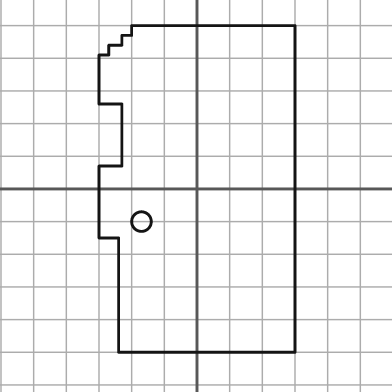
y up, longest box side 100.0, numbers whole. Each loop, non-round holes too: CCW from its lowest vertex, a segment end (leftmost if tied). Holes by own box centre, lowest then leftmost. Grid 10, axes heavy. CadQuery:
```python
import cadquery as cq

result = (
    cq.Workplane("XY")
    .moveTo(-24.0, -50.0)
    .lineTo(30.0, -50.0)
    .lineTo(30.0, 50.0)
    .lineTo(-20.0, 50.0)
    .lineTo(-20.0, 47.0)
    .lineTo(-23.0, 47.0)
    .lineTo(-23.0, 44.0)
    .lineTo(-27.0, 44.0)
    .lineTo(-27.0, 41.0)
    .lineTo(-30.0, 41.0)
    .lineTo(-30.0, 26.0)
    .lineTo(-23.0, 26.0)
    .lineTo(-23.0, 7.0)
    .lineTo(-30.0, 7.0)
    .lineTo(-30.0, -15.0)
    .lineTo(-24.0, -15.0)
    .close()
    .moveTo(-17.0, -10.0)
    .circle(3.0)
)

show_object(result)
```